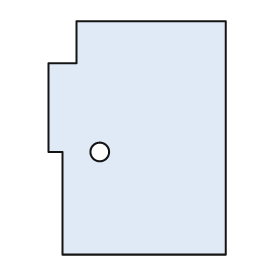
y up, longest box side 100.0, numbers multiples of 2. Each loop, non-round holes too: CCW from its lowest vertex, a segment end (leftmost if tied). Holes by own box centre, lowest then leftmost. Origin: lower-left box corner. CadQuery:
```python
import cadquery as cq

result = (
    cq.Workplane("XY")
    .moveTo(6.0, 0.0)
    .lineTo(76.0, 0.0)
    .lineTo(76.0, 100.0)
    .lineTo(12.0, 100.0)
    .lineTo(12.0, 82.0)
    .lineTo(0.0, 82.0)
    .lineTo(0.0, 44.0)
    .lineTo(6.0, 44.0)
    .close()
    .moveTo(22.0, 44.0)
    .circle(4.0)
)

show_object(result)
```